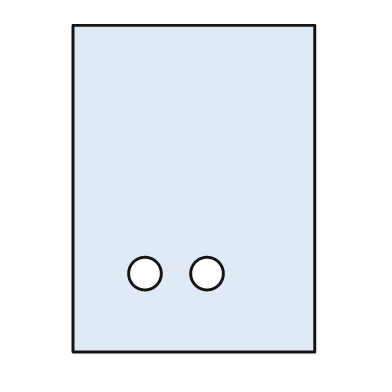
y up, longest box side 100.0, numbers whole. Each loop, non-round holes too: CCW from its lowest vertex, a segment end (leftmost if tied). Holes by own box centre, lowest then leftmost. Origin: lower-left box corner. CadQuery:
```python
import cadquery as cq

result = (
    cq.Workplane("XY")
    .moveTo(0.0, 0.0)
    .lineTo(74.0, 0.0)
    .lineTo(74.0, 100.0)
    .lineTo(0.0, 100.0)
    .close()
    .moveTo(22.0, 24.0)
    .circle(5.0)
    .moveTo(41.0, 24.0)
    .circle(5.0)
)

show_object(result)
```